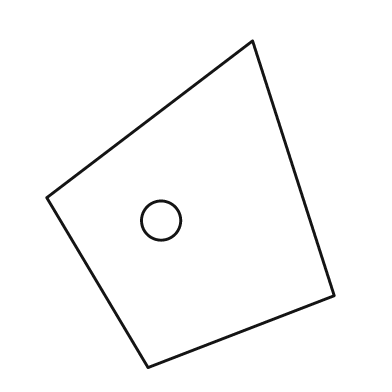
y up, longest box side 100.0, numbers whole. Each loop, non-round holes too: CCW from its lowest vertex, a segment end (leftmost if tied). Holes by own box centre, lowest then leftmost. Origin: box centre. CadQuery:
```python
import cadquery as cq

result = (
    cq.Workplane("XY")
    .moveTo(-13.0, -50.0)
    .lineTo(44.0, -28.0)
    .lineTo(19.0, 50.0)
    .lineTo(-44.0, 2.0)
    .close()
    .moveTo(-9.0, -5.0)
    .circle(6.0)
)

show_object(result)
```